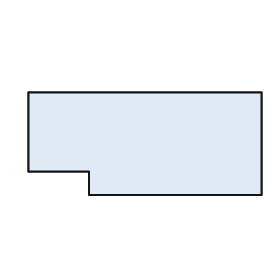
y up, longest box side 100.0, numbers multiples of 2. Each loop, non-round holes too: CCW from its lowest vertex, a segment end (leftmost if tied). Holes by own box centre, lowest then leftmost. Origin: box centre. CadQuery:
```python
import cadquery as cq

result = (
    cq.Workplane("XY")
    .moveTo(-24.0, -22.0)
    .lineTo(50.0, -22.0)
    .lineTo(50.0, 22.0)
    .lineTo(-50.0, 22.0)
    .lineTo(-50.0, -12.0)
    .lineTo(-24.0, -12.0)
    .close()
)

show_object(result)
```